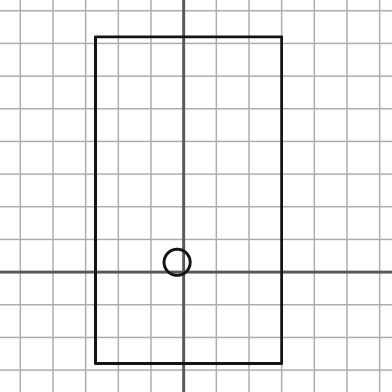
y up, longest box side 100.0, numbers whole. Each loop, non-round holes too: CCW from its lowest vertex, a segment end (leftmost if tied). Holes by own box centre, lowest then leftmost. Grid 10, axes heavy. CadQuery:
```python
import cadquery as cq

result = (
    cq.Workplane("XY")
    .moveTo(-27.0, -28.0)
    .lineTo(30.0, -28.0)
    .lineTo(30.0, 72.0)
    .lineTo(-27.0, 72.0)
    .close()
    .moveTo(-2.0, 3.0)
    .circle(4.0)
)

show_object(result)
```